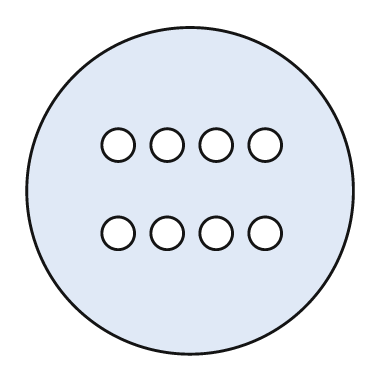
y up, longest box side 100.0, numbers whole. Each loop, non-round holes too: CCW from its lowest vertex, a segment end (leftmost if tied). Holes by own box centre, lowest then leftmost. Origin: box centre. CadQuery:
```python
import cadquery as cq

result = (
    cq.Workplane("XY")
    .moveTo(0.0, 0.0)
    .circle(50.0)
    .moveTo(-22.0, -13.0)
    .circle(5.0)
    .moveTo(-7.0, -13.0)
    .circle(5.0)
    .moveTo(8.0, -13.0)
    .circle(5.0)
    .moveTo(23.0, -13.0)
    .circle(5.0)
    .moveTo(-22.0, 14.0)
    .circle(5.0)
    .moveTo(-7.0, 14.0)
    .circle(5.0)
    .moveTo(8.0, 14.0)
    .circle(5.0)
    .moveTo(23.0, 14.0)
    .circle(5.0)
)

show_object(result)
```